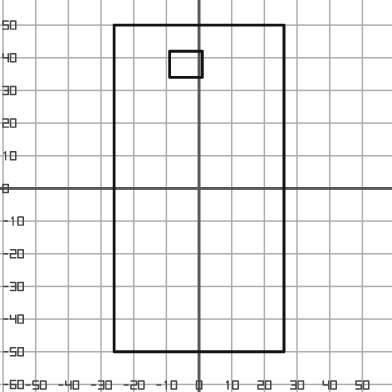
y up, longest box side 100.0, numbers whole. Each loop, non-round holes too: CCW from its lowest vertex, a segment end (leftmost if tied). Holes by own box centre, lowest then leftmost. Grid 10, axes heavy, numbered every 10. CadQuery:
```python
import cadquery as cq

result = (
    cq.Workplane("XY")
    .moveTo(-26.0, -50.0)
    .lineTo(26.0, -50.0)
    .lineTo(26.0, 50.0)
    .lineTo(-26.0, 50.0)
    .close()
    .moveTo(-9.0, 34.0)
    .lineTo(1.0, 34.0)
    .lineTo(1.0, 42.0)
    .lineTo(-9.0, 42.0)
    .close()
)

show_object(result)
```